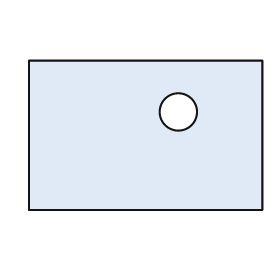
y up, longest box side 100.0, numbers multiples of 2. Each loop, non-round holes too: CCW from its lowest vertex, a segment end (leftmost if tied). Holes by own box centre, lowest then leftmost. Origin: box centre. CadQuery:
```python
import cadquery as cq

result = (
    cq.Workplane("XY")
    .moveTo(-50.0, -32.0)
    .lineTo(50.0, -32.0)
    .lineTo(50.0, 32.0)
    .lineTo(-50.0, 32.0)
    .close()
    .moveTo(14.0, 10.0)
    .circle(8.0)
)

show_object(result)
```